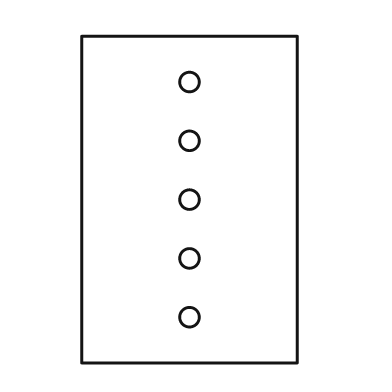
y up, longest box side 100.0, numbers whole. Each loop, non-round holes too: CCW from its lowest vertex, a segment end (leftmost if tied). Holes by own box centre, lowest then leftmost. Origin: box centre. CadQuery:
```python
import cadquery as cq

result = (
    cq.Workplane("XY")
    .moveTo(-33.0, -50.0)
    .lineTo(33.0, -50.0)
    .lineTo(33.0, 50.0)
    .lineTo(-33.0, 50.0)
    .close()
    .moveTo(0.0, -36.0)
    .circle(3.0)
    .moveTo(0.0, -18.0)
    .circle(3.0)
    .moveTo(0.0, 0.0)
    .circle(3.0)
    .moveTo(0.0, 18.0)
    .circle(3.0)
    .moveTo(0.0, 36.0)
    .circle(3.0)
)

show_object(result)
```